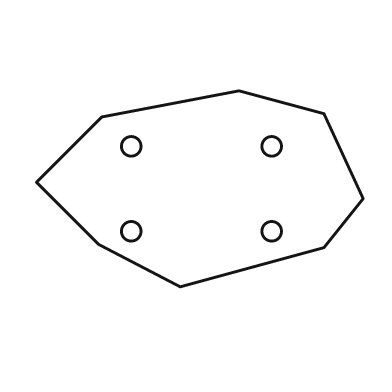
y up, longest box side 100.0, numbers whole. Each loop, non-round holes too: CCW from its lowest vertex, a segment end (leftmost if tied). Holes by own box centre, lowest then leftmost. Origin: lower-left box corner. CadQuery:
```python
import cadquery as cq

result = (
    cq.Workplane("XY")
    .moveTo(44.0, 0.0)
    .lineTo(88.0, 12.0)
    .lineTo(100.0, 27.0)
    .lineTo(88.0, 53.0)
    .lineTo(62.0, 60.0)
    .lineTo(20.0, 52.0)
    .lineTo(0.0, 32.0)
    .lineTo(19.0, 13.0)
    .close()
    .moveTo(29.0, 17.0)
    .circle(3.0)
    .moveTo(72.0, 17.0)
    .circle(3.0)
    .moveTo(29.0, 43.0)
    .circle(3.0)
    .moveTo(72.0, 43.0)
    .circle(3.0)
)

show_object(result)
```